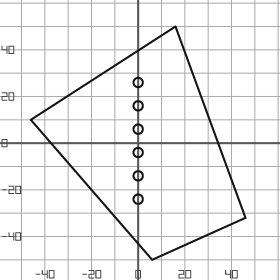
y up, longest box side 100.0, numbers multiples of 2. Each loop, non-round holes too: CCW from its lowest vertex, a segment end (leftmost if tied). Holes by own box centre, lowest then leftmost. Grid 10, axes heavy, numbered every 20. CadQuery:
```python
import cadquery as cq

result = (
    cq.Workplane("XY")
    .moveTo(6.0, -50.0)
    .lineTo(46.0, -32.0)
    .lineTo(16.0, 50.0)
    .lineTo(-46.0, 10.0)
    .close()
    .moveTo(0.0, -24.0)
    .circle(2.0)
    .moveTo(0.0, -14.0)
    .circle(2.0)
    .moveTo(0.0, -4.0)
    .circle(2.0)
    .moveTo(0.0, 6.0)
    .circle(2.0)
    .moveTo(0.0, 16.0)
    .circle(2.0)
    .moveTo(0.0, 26.0)
    .circle(2.0)
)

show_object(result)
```